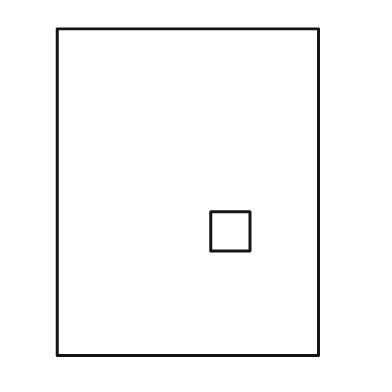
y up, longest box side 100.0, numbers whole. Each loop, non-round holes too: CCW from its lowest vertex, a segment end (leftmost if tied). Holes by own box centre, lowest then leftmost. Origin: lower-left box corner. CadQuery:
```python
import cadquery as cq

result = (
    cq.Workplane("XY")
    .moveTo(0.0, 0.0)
    .lineTo(80.0, 0.0)
    .lineTo(80.0, 100.0)
    .lineTo(0.0, 100.0)
    .close()
    .moveTo(47.0, 32.0)
    .lineTo(59.0, 32.0)
    .lineTo(59.0, 44.0)
    .lineTo(47.0, 44.0)
    .close()
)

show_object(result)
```